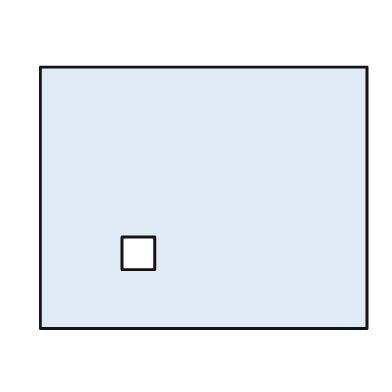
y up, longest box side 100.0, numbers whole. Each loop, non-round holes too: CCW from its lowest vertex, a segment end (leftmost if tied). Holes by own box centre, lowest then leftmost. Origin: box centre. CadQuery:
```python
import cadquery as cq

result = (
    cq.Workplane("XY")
    .moveTo(-50.0, -40.0)
    .lineTo(50.0, -40.0)
    .lineTo(50.0, 40.0)
    .lineTo(-50.0, 40.0)
    .close()
    .moveTo(-25.0, -22.0)
    .lineTo(-15.0, -22.0)
    .lineTo(-15.0, -12.0)
    .lineTo(-25.0, -12.0)
    .close()
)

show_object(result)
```